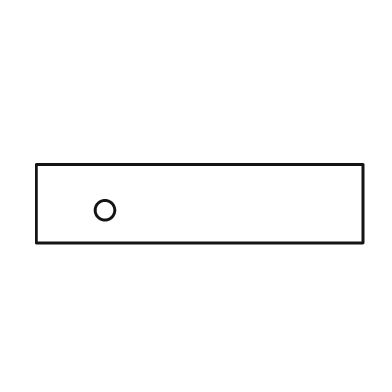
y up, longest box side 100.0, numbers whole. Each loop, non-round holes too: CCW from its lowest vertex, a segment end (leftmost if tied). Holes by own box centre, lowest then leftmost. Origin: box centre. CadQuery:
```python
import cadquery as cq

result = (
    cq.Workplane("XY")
    .moveTo(-50.0, -12.0)
    .lineTo(50.0, -12.0)
    .lineTo(50.0, 12.0)
    .lineTo(-50.0, 12.0)
    .close()
    .moveTo(-29.0, -2.0)
    .circle(3.0)
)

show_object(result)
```